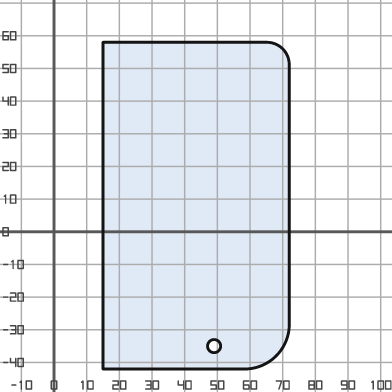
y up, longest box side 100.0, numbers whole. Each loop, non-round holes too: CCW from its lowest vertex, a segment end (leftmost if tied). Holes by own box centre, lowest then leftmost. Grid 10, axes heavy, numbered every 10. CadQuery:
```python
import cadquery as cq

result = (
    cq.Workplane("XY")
    .moveTo(15.0, -42.0)
    .lineTo(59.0, -42.0)
    .threePointArc((68.0, -38.0), (72.0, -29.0))
    .lineTo(72.0, 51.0)
    .threePointArc((70.0, 56.0), (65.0, 58.0))
    .lineTo(15.0, 58.0)
    .close()
    .moveTo(49.0, -35.0)
    .circle(2.0)
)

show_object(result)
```